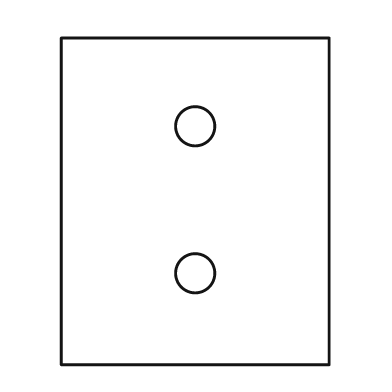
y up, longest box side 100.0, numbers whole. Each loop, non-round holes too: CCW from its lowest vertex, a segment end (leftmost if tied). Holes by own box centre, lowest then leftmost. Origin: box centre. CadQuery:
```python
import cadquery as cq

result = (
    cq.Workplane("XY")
    .moveTo(-41.0, -50.0)
    .lineTo(41.0, -50.0)
    .lineTo(41.0, 50.0)
    .lineTo(-41.0, 50.0)
    .close()
    .moveTo(0.0, -22.0)
    .circle(6.0)
    .moveTo(0.0, 23.0)
    .circle(6.0)
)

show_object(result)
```